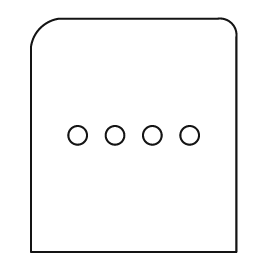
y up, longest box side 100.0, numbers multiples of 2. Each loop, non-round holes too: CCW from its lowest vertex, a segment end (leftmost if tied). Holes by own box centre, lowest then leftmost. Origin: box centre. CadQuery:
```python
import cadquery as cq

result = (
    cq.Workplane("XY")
    .moveTo(-44.0, -50.0)
    .lineTo(44.0, -50.0)
    .lineTo(44.0, 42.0)
    .threePointArc((42.0, 48.0), (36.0, 50.0))
    .lineTo(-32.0, 50.0)
    .threePointArc((-40.0, 46.0), (-44.0, 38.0))
    .close()
    .moveTo(-24.0, 0.0)
    .circle(4.0)
    .moveTo(-8.0, 0.0)
    .circle(4.0)
    .moveTo(8.0, 0.0)
    .circle(4.0)
    .moveTo(24.0, 0.0)
    .circle(4.0)
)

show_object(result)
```